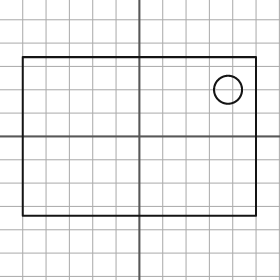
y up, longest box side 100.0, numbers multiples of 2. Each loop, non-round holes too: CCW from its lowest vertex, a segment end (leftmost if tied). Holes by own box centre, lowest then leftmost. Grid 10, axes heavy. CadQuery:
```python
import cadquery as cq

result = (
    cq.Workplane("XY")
    .moveTo(-50.0, -34.0)
    .lineTo(50.0, -34.0)
    .lineTo(50.0, 34.0)
    .lineTo(-50.0, 34.0)
    .close()
    .moveTo(38.0, 20.0)
    .circle(6.0)
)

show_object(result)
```